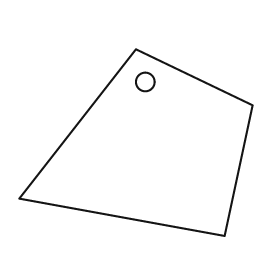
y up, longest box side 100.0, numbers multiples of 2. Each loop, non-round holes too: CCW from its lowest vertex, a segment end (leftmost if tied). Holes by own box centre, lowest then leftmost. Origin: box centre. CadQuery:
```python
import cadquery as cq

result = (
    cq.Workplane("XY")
    .moveTo(38.0, -40.0)
    .lineTo(50.0, 16.0)
    .lineTo(0.0, 40.0)
    .lineTo(-50.0, -24.0)
    .close()
    .moveTo(4.0, 26.0)
    .circle(4.0)
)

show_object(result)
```